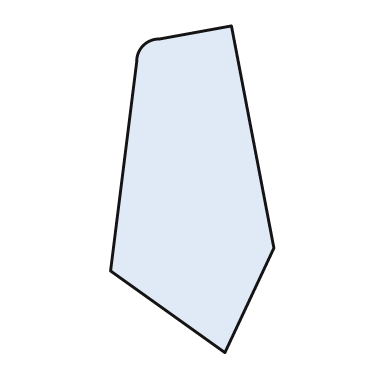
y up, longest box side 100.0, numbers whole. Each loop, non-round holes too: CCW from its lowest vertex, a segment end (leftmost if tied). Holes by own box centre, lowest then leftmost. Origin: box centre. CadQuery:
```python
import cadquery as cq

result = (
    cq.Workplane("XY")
    .moveTo(10.0, -50.0)
    .lineTo(25.0, -18.0)
    .lineTo(12.0, 50.0)
    .lineTo(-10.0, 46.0)
    .threePointArc((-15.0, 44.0), (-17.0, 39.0))
    .lineTo(-25.0, -25.0)
    .close()
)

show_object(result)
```